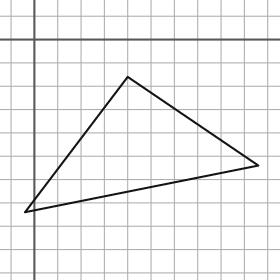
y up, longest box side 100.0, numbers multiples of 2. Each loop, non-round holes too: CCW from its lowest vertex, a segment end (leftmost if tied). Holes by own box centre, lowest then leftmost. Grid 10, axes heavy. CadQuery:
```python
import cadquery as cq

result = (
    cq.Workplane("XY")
    .moveTo(-4.0, -74.0)
    .lineTo(96.0, -54.0)
    .lineTo(40.0, -16.0)
    .close()
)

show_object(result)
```